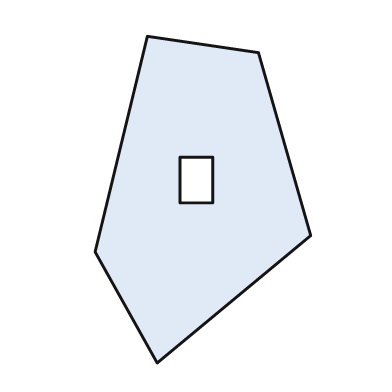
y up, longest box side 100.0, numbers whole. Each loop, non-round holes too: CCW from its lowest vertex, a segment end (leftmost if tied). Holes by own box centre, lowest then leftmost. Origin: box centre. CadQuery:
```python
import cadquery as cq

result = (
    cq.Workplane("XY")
    .moveTo(-14.0, -50.0)
    .lineTo(33.0, -11.0)
    .lineTo(17.0, 45.0)
    .lineTo(-17.0, 50.0)
    .lineTo(-33.0, -16.0)
    .close()
    .moveTo(-7.0, -1.0)
    .lineTo(3.0, -1.0)
    .lineTo(3.0, 13.0)
    .lineTo(-7.0, 13.0)
    .close()
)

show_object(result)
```